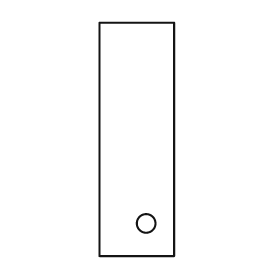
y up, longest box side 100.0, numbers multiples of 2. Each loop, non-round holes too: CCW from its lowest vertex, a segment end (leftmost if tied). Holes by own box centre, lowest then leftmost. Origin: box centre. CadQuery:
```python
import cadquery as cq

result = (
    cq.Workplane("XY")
    .moveTo(-16.0, -50.0)
    .lineTo(16.0, -50.0)
    .lineTo(16.0, 50.0)
    .lineTo(-16.0, 50.0)
    .close()
    .moveTo(4.0, -36.0)
    .circle(4.0)
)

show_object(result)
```